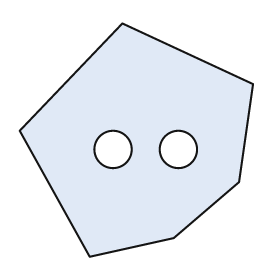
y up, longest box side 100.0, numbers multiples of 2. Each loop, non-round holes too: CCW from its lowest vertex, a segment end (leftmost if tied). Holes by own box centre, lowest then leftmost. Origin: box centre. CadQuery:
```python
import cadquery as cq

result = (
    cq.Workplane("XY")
    .moveTo(-20.0, -50.0)
    .lineTo(16.0, -42.0)
    .lineTo(44.0, -18.0)
    .lineTo(50.0, 24.0)
    .lineTo(-6.0, 50.0)
    .lineTo(-50.0, 4.0)
    .close()
    .moveTo(-10.0, -4.0)
    .circle(8.0)
    .moveTo(18.0, -4.0)
    .circle(8.0)
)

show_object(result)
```